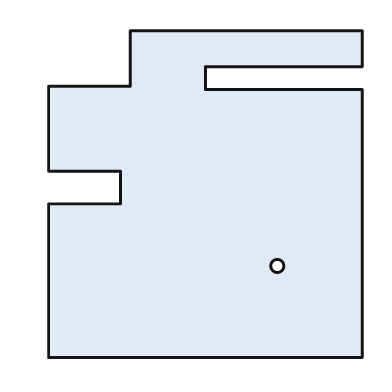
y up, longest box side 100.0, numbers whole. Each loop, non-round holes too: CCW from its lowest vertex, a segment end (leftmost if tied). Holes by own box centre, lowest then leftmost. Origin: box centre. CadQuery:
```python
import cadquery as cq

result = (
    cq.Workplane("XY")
    .moveTo(-48.0, -50.0)
    .lineTo(48.0, -50.0)
    .lineTo(48.0, 32.0)
    .lineTo(0.0, 32.0)
    .lineTo(0.0, 39.0)
    .lineTo(48.0, 39.0)
    .lineTo(48.0, 50.0)
    .lineTo(-23.0, 50.0)
    .lineTo(-23.0, 33.0)
    .lineTo(-48.0, 33.0)
    .lineTo(-48.0, 7.0)
    .lineTo(-26.0, 7.0)
    .lineTo(-26.0, -3.0)
    .lineTo(-48.0, -3.0)
    .close()
    .moveTo(22.0, -22.0)
    .circle(2.0)
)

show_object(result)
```